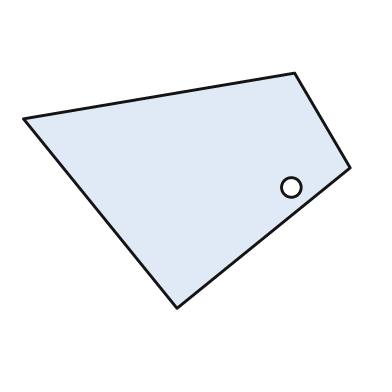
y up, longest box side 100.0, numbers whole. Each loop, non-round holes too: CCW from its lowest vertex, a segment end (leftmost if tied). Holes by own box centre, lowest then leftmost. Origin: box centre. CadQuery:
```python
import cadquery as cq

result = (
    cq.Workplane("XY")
    .moveTo(-3.0, -36.0)
    .lineTo(50.0, 7.0)
    .lineTo(33.0, 36.0)
    .lineTo(-50.0, 22.0)
    .close()
    .moveTo(32.0, 1.0)
    .circle(3.0)
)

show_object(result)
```